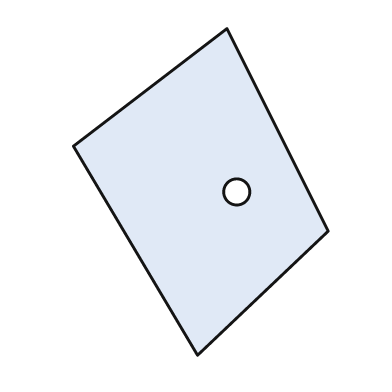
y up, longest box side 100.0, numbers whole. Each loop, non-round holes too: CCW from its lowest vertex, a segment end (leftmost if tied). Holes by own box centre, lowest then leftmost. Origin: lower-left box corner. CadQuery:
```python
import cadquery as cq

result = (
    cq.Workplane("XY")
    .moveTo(38.0, 0.0)
    .lineTo(78.0, 38.0)
    .lineTo(47.0, 100.0)
    .lineTo(0.0, 64.0)
    .close()
    .moveTo(50.0, 50.0)
    .circle(4.0)
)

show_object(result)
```